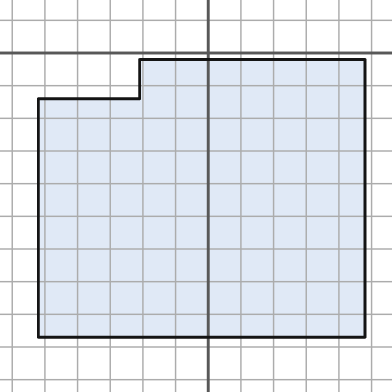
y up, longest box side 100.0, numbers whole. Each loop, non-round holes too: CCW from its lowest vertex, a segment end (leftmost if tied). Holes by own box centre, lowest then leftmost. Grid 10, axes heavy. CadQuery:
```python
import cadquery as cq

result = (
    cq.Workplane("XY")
    .moveTo(-52.0, -87.0)
    .lineTo(48.0, -87.0)
    .lineTo(48.0, -2.0)
    .lineTo(-21.0, -2.0)
    .lineTo(-21.0, -14.0)
    .lineTo(-52.0, -14.0)
    .close()
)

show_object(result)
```